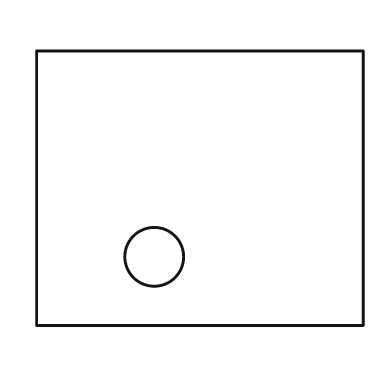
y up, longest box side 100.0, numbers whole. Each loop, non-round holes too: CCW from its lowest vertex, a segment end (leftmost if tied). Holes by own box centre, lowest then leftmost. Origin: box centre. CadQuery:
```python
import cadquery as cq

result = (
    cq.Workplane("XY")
    .moveTo(-50.0, -42.0)
    .lineTo(50.0, -42.0)
    .lineTo(50.0, 42.0)
    .lineTo(-50.0, 42.0)
    .close()
    .moveTo(-14.0, -21.0)
    .circle(9.0)
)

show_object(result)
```